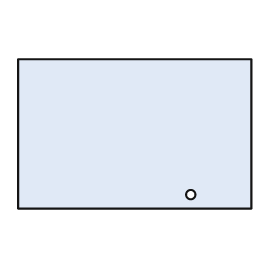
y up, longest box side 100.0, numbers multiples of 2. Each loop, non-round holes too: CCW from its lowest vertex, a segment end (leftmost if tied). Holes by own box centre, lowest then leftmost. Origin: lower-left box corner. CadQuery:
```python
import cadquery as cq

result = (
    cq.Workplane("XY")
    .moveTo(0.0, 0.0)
    .lineTo(100.0, 0.0)
    .lineTo(100.0, 64.0)
    .lineTo(0.0, 64.0)
    .close()
    .moveTo(74.0, 6.0)
    .circle(2.0)
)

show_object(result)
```